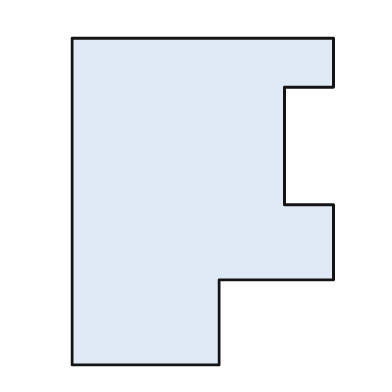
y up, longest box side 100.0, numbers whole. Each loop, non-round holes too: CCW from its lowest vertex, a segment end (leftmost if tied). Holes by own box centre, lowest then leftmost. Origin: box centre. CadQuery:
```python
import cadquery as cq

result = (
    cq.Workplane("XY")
    .moveTo(-40.0, -50.0)
    .lineTo(5.0, -50.0)
    .lineTo(5.0, -24.0)
    .lineTo(40.0, -24.0)
    .lineTo(40.0, -1.0)
    .lineTo(25.0, -1.0)
    .lineTo(25.0, 35.0)
    .lineTo(40.0, 35.0)
    .lineTo(40.0, 50.0)
    .lineTo(-40.0, 50.0)
    .close()
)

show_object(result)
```